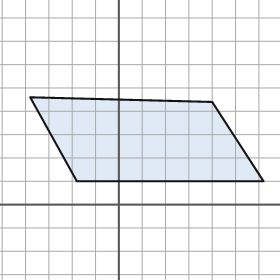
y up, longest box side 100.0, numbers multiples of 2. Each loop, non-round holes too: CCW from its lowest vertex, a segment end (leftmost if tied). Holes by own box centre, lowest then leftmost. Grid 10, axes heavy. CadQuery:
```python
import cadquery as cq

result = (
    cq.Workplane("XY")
    .moveTo(-18.0, 10.0)
    .lineTo(62.0, 10.0)
    .lineTo(40.0, 44.0)
    .lineTo(-38.0, 46.0)
    .close()
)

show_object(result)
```